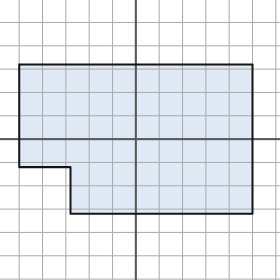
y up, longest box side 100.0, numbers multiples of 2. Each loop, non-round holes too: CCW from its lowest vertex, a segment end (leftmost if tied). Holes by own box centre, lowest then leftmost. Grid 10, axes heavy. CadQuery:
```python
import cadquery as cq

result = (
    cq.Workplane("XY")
    .moveTo(-28.0, -32.0)
    .lineTo(50.0, -32.0)
    .lineTo(50.0, 32.0)
    .lineTo(-50.0, 32.0)
    .lineTo(-50.0, -12.0)
    .lineTo(-28.0, -12.0)
    .close()
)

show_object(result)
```